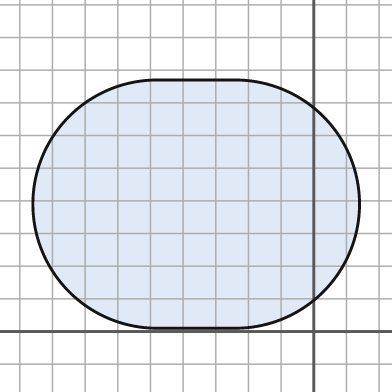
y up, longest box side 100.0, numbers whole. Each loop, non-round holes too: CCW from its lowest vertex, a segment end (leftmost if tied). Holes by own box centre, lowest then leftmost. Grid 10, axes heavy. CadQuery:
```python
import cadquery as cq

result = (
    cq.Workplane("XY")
    .moveTo(-48.0, 1.0)
    .lineTo(-24.0, 1.0)
    .threePointArc((14.0, 39.0), (-24.0, 77.0))
    .lineTo(-48.0, 77.0)
    .threePointArc((-86.0, 39.0), (-48.0, 1.0))
    .close()
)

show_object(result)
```